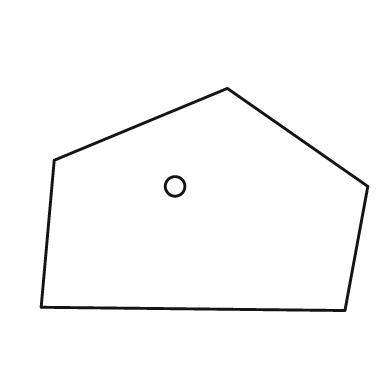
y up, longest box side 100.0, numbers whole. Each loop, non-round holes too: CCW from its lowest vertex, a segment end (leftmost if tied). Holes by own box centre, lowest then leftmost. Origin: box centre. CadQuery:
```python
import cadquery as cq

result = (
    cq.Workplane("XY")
    .moveTo(43.0, -34.0)
    .lineTo(50.0, 4.0)
    .lineTo(7.0, 34.0)
    .lineTo(-46.0, 12.0)
    .lineTo(-50.0, -33.0)
    .close()
    .moveTo(-9.0, 4.0)
    .circle(3.0)
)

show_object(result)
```